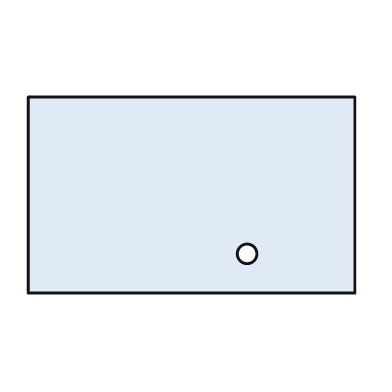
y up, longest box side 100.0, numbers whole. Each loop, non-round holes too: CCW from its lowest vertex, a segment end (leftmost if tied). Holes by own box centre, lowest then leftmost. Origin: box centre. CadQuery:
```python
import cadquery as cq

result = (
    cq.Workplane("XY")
    .moveTo(-50.0, -30.0)
    .lineTo(50.0, -30.0)
    .lineTo(50.0, 30.0)
    .lineTo(-50.0, 30.0)
    .close()
    .moveTo(17.0, -18.0)
    .circle(3.0)
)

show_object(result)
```